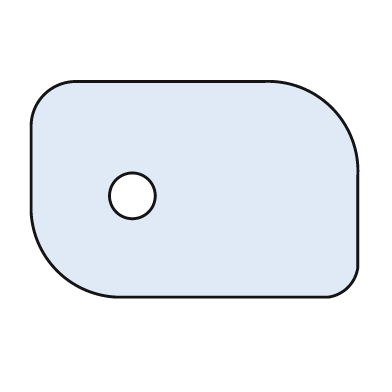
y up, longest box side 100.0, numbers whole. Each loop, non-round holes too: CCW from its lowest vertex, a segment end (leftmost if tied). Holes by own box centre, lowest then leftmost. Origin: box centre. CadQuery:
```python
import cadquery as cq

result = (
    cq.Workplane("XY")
    .moveTo(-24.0, -33.0)
    .lineTo(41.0, -33.0)
    .threePointArc((47.0, -30.0), (50.0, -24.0))
    .lineTo(50.0, 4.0)
    .threePointArc((42.0, 25.0), (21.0, 33.0))
    .lineTo(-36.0, 33.0)
    .threePointArc((-46.0, 29.0), (-50.0, 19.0))
    .lineTo(-50.0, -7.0)
    .threePointArc((-42.0, -25.0), (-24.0, -33.0))
    .close()
    .moveTo(-19.0, -2.0)
    .circle(7.0)
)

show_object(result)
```